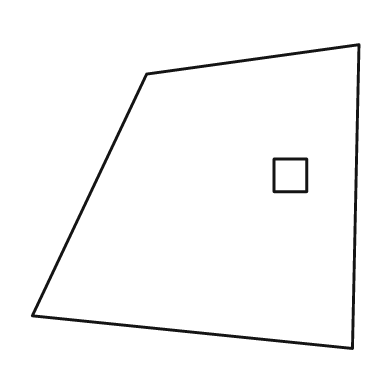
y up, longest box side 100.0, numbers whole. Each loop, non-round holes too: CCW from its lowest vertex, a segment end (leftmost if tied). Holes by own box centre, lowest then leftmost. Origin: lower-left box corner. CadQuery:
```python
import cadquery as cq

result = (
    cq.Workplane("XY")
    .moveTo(98.0, 0.0)
    .lineTo(100.0, 93.0)
    .lineTo(35.0, 84.0)
    .lineTo(0.0, 10.0)
    .close()
    .moveTo(74.0, 48.0)
    .lineTo(84.0, 48.0)
    .lineTo(84.0, 58.0)
    .lineTo(74.0, 58.0)
    .close()
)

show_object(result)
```